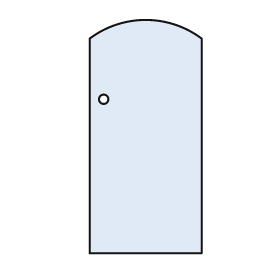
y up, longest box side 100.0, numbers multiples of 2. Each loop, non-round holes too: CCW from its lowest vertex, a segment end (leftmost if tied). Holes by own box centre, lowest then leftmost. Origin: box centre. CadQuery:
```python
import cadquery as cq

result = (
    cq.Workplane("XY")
    .moveTo(-24.0, -50.0)
    .lineTo(24.0, -50.0)
    .lineTo(24.0, 42.0)
    .threePointArc((0.0, 50.0), (-24.0, 42.0))
    .close()
    .moveTo(-18.0, 16.0)
    .circle(2.0)
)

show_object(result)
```